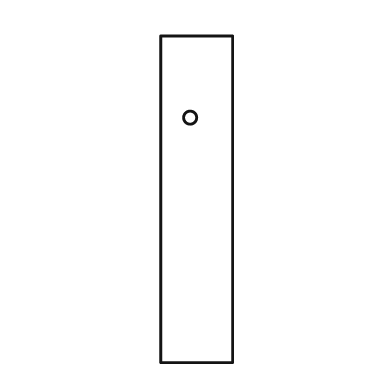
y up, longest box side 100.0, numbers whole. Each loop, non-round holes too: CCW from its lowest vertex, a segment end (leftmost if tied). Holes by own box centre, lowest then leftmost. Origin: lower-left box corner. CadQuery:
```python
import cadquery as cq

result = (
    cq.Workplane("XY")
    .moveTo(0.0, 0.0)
    .lineTo(22.0, 0.0)
    .lineTo(22.0, 100.0)
    .lineTo(0.0, 100.0)
    .close()
    .moveTo(9.0, 75.0)
    .circle(2.0)
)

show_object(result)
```